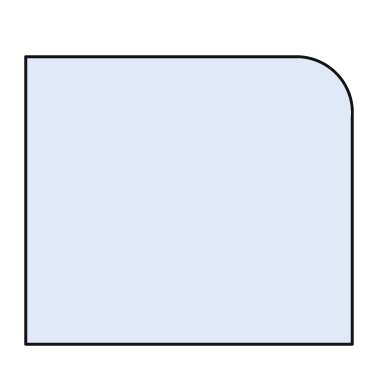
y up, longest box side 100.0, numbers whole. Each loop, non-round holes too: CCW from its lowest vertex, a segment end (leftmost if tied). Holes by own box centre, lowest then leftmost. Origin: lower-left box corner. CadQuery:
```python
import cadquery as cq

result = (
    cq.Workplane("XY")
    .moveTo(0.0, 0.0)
    .lineTo(100.0, 0.0)
    .lineTo(100.0, 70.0)
    .threePointArc((95.0, 83.0), (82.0, 88.0))
    .lineTo(0.0, 88.0)
    .close()
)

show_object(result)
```